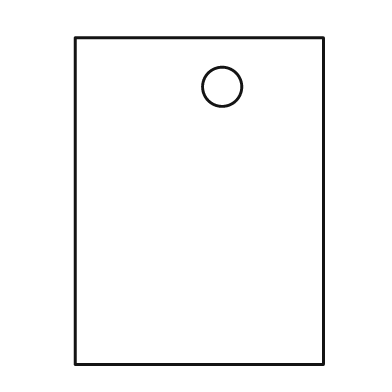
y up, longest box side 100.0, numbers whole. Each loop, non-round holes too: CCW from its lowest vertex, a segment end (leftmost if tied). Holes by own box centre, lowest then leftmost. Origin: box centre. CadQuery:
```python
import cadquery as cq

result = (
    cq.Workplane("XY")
    .moveTo(-38.0, -50.0)
    .lineTo(38.0, -50.0)
    .lineTo(38.0, 50.0)
    .lineTo(-38.0, 50.0)
    .close()
    .moveTo(7.0, 35.0)
    .circle(6.0)
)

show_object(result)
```